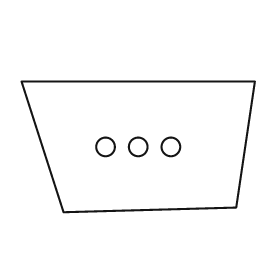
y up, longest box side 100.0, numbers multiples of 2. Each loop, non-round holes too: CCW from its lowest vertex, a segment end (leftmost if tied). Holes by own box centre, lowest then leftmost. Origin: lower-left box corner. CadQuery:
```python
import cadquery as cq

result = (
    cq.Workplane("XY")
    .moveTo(18.0, 0.0)
    .lineTo(92.0, 2.0)
    .lineTo(100.0, 56.0)
    .lineTo(0.0, 56.0)
    .close()
    .moveTo(36.0, 28.0)
    .circle(4.0)
    .moveTo(50.0, 28.0)
    .circle(4.0)
    .moveTo(64.0, 28.0)
    .circle(4.0)
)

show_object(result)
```